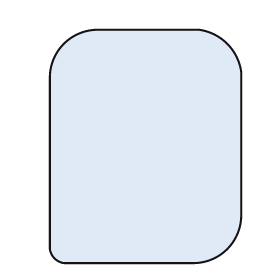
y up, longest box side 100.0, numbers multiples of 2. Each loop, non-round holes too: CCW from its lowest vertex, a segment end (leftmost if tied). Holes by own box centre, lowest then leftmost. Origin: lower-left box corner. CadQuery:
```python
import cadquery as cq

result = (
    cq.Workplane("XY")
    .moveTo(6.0, 0.0)
    .lineTo(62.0, 0.0)
    .threePointArc((76.0, 6.0), (82.0, 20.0))
    .lineTo(82.0, 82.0)
    .threePointArc((76.0, 94.0), (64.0, 100.0))
    .lineTo(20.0, 100.0)
    .threePointArc((6.0, 94.0), (0.0, 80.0))
    .lineTo(0.0, 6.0)
    .threePointArc((2.0, 2.0), (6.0, 0.0))
    .close()
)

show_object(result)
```